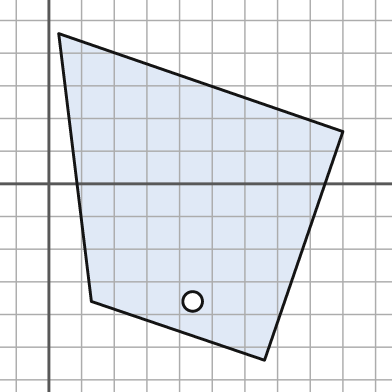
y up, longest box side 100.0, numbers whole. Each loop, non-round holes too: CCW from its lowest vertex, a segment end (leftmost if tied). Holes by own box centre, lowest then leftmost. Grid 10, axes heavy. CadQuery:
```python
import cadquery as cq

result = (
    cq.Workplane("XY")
    .moveTo(66.0, -54.0)
    .lineTo(90.0, 16.0)
    .lineTo(3.0, 46.0)
    .lineTo(13.0, -36.0)
    .close()
    .moveTo(44.0, -36.0)
    .circle(3.0)
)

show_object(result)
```